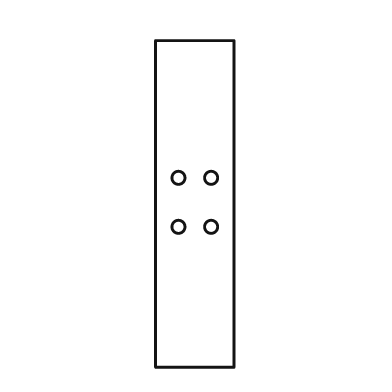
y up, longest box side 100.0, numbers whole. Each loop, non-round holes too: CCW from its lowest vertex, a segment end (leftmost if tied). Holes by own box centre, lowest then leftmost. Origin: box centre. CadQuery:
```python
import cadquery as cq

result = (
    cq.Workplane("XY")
    .moveTo(-12.0, -50.0)
    .lineTo(12.0, -50.0)
    .lineTo(12.0, 50.0)
    .lineTo(-12.0, 50.0)
    .close()
    .moveTo(-5.0, -7.0)
    .circle(2.0)
    .moveTo(5.0, -7.0)
    .circle(2.0)
    .moveTo(-5.0, 8.0)
    .circle(2.0)
    .moveTo(5.0, 8.0)
    .circle(2.0)
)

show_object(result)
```